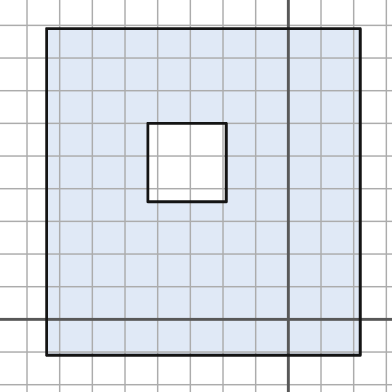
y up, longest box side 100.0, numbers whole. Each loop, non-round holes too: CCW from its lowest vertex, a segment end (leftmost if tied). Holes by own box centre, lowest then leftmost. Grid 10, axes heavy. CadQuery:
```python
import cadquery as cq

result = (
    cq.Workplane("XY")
    .moveTo(-74.0, -11.0)
    .lineTo(22.0, -11.0)
    .lineTo(22.0, 89.0)
    .lineTo(-74.0, 89.0)
    .close()
    .moveTo(-43.0, 36.0)
    .lineTo(-19.0, 36.0)
    .lineTo(-19.0, 60.0)
    .lineTo(-43.0, 60.0)
    .close()
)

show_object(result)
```